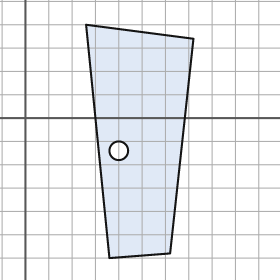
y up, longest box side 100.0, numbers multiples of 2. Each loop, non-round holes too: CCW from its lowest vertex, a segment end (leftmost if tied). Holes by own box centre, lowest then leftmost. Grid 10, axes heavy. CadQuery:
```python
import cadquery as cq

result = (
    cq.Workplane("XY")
    .moveTo(36.0, -60.0)
    .lineTo(62.0, -58.0)
    .lineTo(72.0, 34.0)
    .lineTo(26.0, 40.0)
    .close()
    .moveTo(40.0, -14.0)
    .circle(4.0)
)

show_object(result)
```